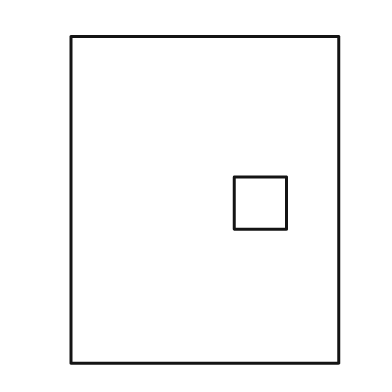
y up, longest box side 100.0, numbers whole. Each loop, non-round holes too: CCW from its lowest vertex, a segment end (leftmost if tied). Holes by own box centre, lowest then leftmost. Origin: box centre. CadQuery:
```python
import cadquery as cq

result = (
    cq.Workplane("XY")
    .moveTo(-41.0, -50.0)
    .lineTo(41.0, -50.0)
    .lineTo(41.0, 50.0)
    .lineTo(-41.0, 50.0)
    .close()
    .moveTo(9.0, -9.0)
    .lineTo(25.0, -9.0)
    .lineTo(25.0, 7.0)
    .lineTo(9.0, 7.0)
    .close()
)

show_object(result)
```